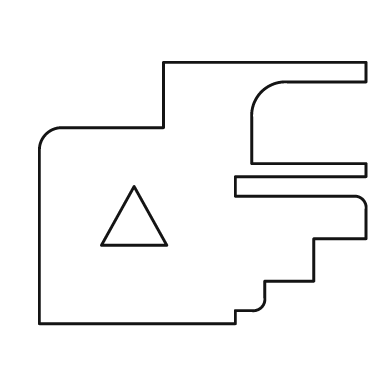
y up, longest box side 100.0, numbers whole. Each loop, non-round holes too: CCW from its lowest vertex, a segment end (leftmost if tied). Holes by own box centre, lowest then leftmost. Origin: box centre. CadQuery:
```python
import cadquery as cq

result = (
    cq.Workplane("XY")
    .moveTo(-50.0, -40.0)
    .lineTo(10.0, -40.0)
    .lineTo(10.0, -36.0)
    .lineTo(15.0, -36.0)
    .threePointArc((18.0, -35.0), (19.0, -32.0))
    .lineTo(19.0, -27.0)
    .lineTo(34.0, -27.0)
    .lineTo(34.0, -14.0)
    .lineTo(50.0, -14.0)
    .lineTo(50.0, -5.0)
    .threePointArc((49.0, -2.0), (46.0, -1.0))
    .lineTo(10.0, -1.0)
    .lineTo(10.0, 5.0)
    .lineTo(50.0, 5.0)
    .lineTo(50.0, 9.0)
    .lineTo(15.0, 9.0)
    .lineTo(15.0, 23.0)
    .threePointArc((18.0, 31.0), (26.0, 34.0))
    .lineTo(50.0, 34.0)
    .lineTo(50.0, 40.0)
    .lineTo(-12.0, 40.0)
    .lineTo(-12.0, 20.0)
    .lineTo(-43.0, 20.0)
    .threePointArc((-48.0, 18.0), (-50.0, 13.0))
    .close()
    .moveTo(-31.0, -16.0)
    .lineTo(-11.0, -16.0)
    .lineTo(-21.0, 2.0)
    .close()
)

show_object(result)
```